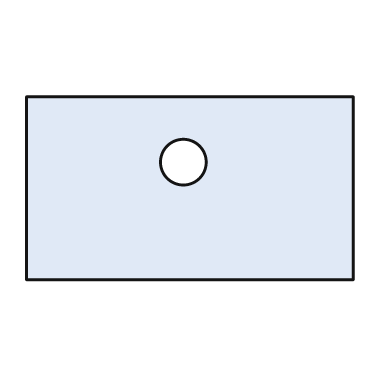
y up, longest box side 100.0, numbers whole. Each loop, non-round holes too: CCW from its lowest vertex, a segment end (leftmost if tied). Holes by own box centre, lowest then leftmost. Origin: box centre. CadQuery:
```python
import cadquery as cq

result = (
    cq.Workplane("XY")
    .moveTo(-50.0, -28.0)
    .lineTo(50.0, -28.0)
    .lineTo(50.0, 28.0)
    .lineTo(-50.0, 28.0)
    .close()
    .moveTo(-2.0, 8.0)
    .circle(7.0)
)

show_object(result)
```